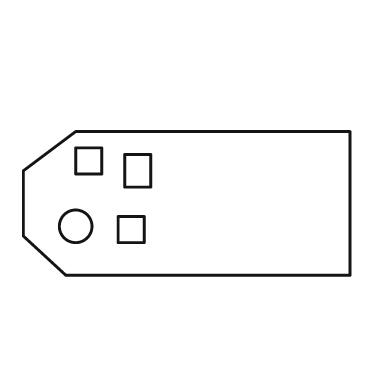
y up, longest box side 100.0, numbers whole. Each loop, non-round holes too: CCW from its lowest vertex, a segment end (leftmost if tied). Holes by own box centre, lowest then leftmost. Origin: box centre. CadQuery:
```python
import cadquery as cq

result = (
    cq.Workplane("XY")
    .moveTo(-37.0, -22.0)
    .lineTo(50.0, -22.0)
    .lineTo(50.0, 22.0)
    .lineTo(-34.0, 22.0)
    .lineTo(-50.0, 10.0)
    .lineTo(-50.0, -10.0)
    .close()
    .moveTo(-21.0, -12.0)
    .lineTo(-13.0, -12.0)
    .lineTo(-13.0, -4.0)
    .lineTo(-21.0, -4.0)
    .close()
    .moveTo(-34.0, -7.0)
    .circle(5.0)
    .moveTo(-19.0, 5.0)
    .lineTo(-11.0, 5.0)
    .lineTo(-11.0, 15.0)
    .lineTo(-19.0, 15.0)
    .close()
    .moveTo(-34.0, 9.0)
    .lineTo(-26.0, 9.0)
    .lineTo(-26.0, 17.0)
    .lineTo(-34.0, 17.0)
    .close()
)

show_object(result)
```